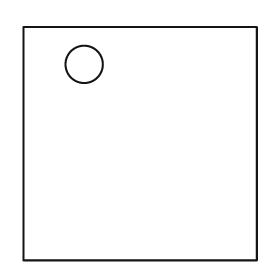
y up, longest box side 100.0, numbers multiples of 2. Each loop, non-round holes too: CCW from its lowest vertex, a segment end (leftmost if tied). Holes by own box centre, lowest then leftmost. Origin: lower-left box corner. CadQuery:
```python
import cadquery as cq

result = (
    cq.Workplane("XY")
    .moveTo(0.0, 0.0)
    .lineTo(100.0, 0.0)
    .lineTo(100.0, 100.0)
    .lineTo(0.0, 100.0)
    .close()
    .moveTo(26.0, 84.0)
    .circle(8.0)
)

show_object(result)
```